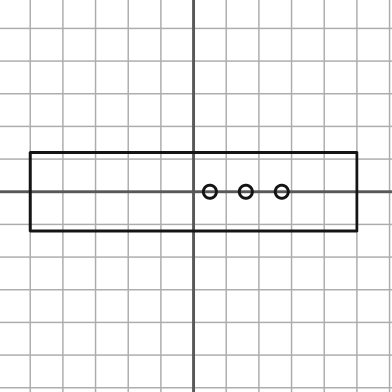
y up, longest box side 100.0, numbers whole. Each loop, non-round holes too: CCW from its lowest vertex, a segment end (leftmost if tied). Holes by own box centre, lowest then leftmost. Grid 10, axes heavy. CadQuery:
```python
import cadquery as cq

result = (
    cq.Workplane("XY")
    .moveTo(-50.0, -12.0)
    .lineTo(50.0, -12.0)
    .lineTo(50.0, 12.0)
    .lineTo(-50.0, 12.0)
    .close()
    .moveTo(5.0, 0.0)
    .circle(2.0)
    .moveTo(16.0, 0.0)
    .circle(2.0)
    .moveTo(27.0, 0.0)
    .circle(2.0)
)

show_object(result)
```